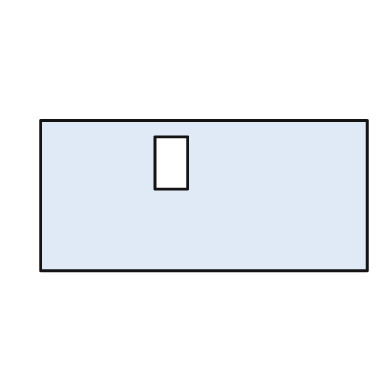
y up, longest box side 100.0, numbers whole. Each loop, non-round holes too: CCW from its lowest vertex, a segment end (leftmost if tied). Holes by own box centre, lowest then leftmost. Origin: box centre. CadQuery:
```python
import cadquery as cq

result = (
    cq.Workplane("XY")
    .moveTo(-50.0, -23.0)
    .lineTo(50.0, -23.0)
    .lineTo(50.0, 23.0)
    .lineTo(-50.0, 23.0)
    .close()
    .moveTo(-15.0, 2.0)
    .lineTo(-5.0, 2.0)
    .lineTo(-5.0, 18.0)
    .lineTo(-15.0, 18.0)
    .close()
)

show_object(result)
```